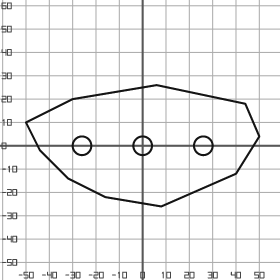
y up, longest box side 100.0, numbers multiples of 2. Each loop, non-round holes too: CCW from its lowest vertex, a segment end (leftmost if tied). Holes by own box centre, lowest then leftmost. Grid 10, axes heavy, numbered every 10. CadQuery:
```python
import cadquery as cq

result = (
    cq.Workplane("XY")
    .moveTo(8.0, -26.0)
    .lineTo(40.0, -12.0)
    .lineTo(50.0, 4.0)
    .lineTo(44.0, 18.0)
    .lineTo(6.0, 26.0)
    .lineTo(-30.0, 20.0)
    .lineTo(-50.0, 10.0)
    .lineTo(-44.0, -2.0)
    .lineTo(-32.0, -14.0)
    .lineTo(-16.0, -22.0)
    .close()
    .moveTo(-26.0, 0.0)
    .circle(4.0)
    .moveTo(0.0, 0.0)
    .circle(4.0)
    .moveTo(26.0, 0.0)
    .circle(4.0)
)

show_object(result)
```